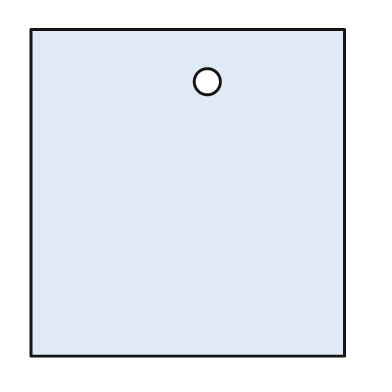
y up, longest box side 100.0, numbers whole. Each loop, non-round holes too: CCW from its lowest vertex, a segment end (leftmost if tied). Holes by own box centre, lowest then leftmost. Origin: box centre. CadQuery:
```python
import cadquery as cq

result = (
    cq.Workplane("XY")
    .moveTo(-48.0, -50.0)
    .lineTo(48.0, -50.0)
    .lineTo(48.0, 50.0)
    .lineTo(-48.0, 50.0)
    .close()
    .moveTo(6.0, 34.0)
    .circle(4.0)
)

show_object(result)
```